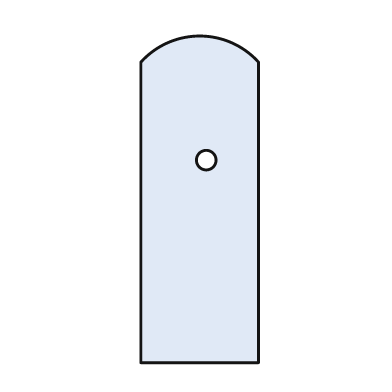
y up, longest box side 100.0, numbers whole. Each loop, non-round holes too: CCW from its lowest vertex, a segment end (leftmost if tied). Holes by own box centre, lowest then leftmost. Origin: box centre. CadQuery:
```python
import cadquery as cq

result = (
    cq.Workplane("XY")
    .moveTo(-18.0, -50.0)
    .lineTo(18.0, -50.0)
    .lineTo(18.0, 42.0)
    .threePointArc((0.0, 50.0), (-18.0, 42.0))
    .close()
    .moveTo(2.0, 12.0)
    .circle(3.0)
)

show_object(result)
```